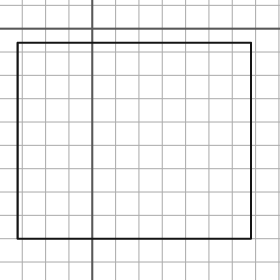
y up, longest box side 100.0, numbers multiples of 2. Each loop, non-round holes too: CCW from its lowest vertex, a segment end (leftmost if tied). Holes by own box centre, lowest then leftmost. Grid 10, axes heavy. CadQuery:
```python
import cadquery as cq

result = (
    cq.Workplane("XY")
    .moveTo(-32.0, -90.0)
    .lineTo(68.0, -90.0)
    .lineTo(68.0, -6.0)
    .lineTo(-32.0, -6.0)
    .close()
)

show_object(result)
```